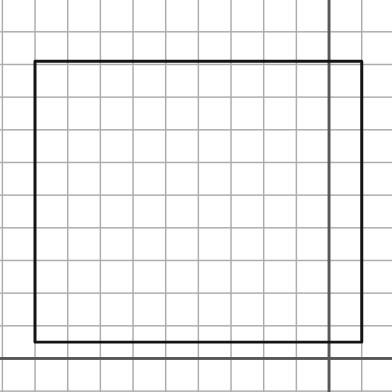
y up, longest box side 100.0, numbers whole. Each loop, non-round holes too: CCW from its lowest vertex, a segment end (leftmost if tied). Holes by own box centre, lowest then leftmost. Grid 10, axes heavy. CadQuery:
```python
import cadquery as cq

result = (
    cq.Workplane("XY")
    .moveTo(-90.0, 5.0)
    .lineTo(10.0, 5.0)
    .lineTo(10.0, 91.0)
    .lineTo(-90.0, 91.0)
    .close()
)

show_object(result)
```